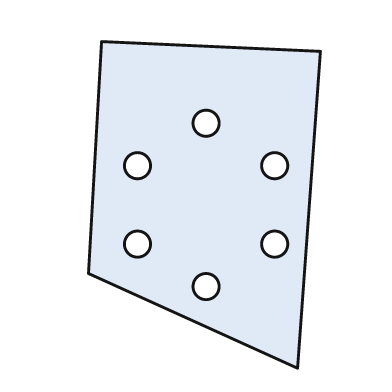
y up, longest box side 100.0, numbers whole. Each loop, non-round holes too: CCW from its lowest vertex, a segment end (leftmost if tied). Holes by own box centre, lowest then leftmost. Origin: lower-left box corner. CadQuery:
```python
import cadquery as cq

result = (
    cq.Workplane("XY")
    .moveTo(64.0, 0.0)
    .lineTo(71.0, 97.0)
    .lineTo(4.0, 100.0)
    .lineTo(0.0, 29.0)
    .close()
    .moveTo(36.0, 25.0)
    .circle(4.0)
    .moveTo(15.0, 38.0)
    .circle(4.0)
    .moveTo(57.0, 38.0)
    .circle(4.0)
    .moveTo(15.0, 62.0)
    .circle(4.0)
    .moveTo(57.0, 62.0)
    .circle(4.0)
    .moveTo(36.0, 75.0)
    .circle(4.0)
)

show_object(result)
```